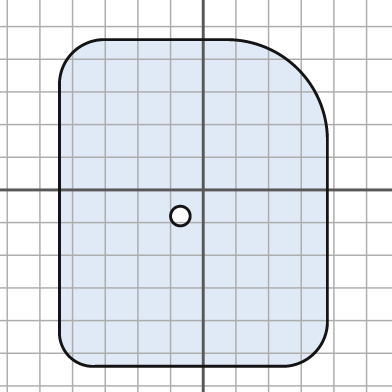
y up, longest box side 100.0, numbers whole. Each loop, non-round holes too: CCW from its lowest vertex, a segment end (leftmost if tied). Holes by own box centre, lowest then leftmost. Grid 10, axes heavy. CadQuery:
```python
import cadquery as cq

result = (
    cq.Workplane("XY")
    .moveTo(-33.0, -54.0)
    .lineTo(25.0, -54.0)
    .threePointArc((34.0, -50.0), (38.0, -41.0))
    .lineTo(38.0, 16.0)
    .threePointArc((29.0, 37.0), (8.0, 46.0))
    .lineTo(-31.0, 46.0)
    .threePointArc((-40.0, 42.0), (-44.0, 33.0))
    .lineTo(-44.0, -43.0)
    .threePointArc((-41.0, -51.0), (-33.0, -54.0))
    .close()
    .moveTo(-7.0, -8.0)
    .circle(3.0)
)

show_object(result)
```